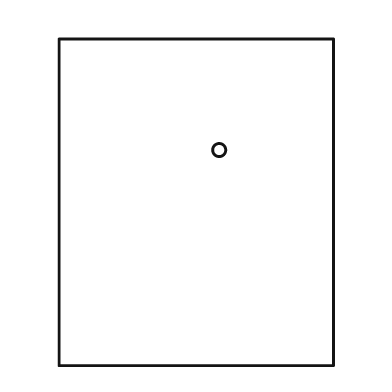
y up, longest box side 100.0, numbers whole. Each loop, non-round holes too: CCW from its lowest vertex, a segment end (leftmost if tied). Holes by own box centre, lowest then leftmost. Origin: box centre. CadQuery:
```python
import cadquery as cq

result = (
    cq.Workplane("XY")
    .moveTo(-42.0, -50.0)
    .lineTo(42.0, -50.0)
    .lineTo(42.0, 50.0)
    .lineTo(-42.0, 50.0)
    .close()
    .moveTo(7.0, 16.0)
    .circle(2.0)
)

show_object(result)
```